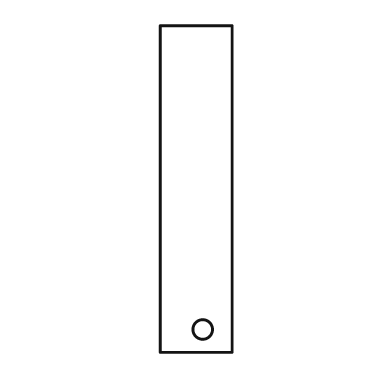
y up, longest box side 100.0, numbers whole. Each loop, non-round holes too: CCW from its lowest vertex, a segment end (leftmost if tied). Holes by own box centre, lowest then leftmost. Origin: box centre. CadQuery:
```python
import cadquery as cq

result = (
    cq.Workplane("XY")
    .moveTo(-11.0, -50.0)
    .lineTo(11.0, -50.0)
    .lineTo(11.0, 50.0)
    .lineTo(-11.0, 50.0)
    .close()
    .moveTo(2.0, -43.0)
    .circle(3.0)
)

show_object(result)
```